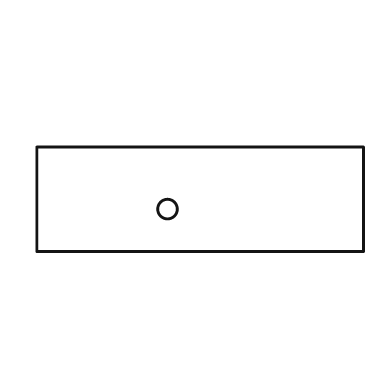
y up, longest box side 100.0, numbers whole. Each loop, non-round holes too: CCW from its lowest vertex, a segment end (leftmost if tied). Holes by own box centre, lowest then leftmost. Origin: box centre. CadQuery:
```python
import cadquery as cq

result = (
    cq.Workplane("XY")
    .moveTo(-50.0, -16.0)
    .lineTo(50.0, -16.0)
    .lineTo(50.0, 16.0)
    .lineTo(-50.0, 16.0)
    .close()
    .moveTo(-10.0, -3.0)
    .circle(3.0)
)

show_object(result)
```